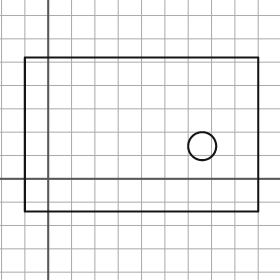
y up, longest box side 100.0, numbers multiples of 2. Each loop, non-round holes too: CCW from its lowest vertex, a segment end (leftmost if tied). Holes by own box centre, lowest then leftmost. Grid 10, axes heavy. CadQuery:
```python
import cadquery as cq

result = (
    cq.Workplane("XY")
    .moveTo(-10.0, -14.0)
    .lineTo(90.0, -14.0)
    .lineTo(90.0, 52.0)
    .lineTo(-10.0, 52.0)
    .close()
    .moveTo(66.0, 14.0)
    .circle(6.0)
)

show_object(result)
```